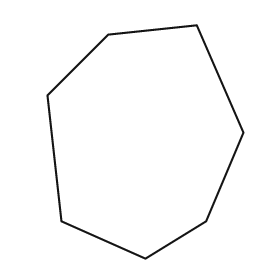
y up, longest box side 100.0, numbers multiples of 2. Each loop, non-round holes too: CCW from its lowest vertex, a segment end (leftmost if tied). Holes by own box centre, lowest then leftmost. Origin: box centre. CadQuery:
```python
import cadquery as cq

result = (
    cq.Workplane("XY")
    .moveTo(0.0, -50.0)
    .lineTo(26.0, -34.0)
    .lineTo(42.0, 4.0)
    .lineTo(22.0, 50.0)
    .lineTo(-16.0, 46.0)
    .lineTo(-42.0, 20.0)
    .lineTo(-36.0, -34.0)
    .close()
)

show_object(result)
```